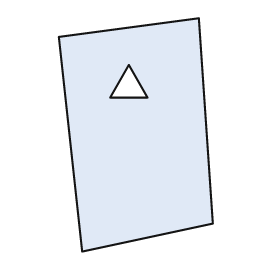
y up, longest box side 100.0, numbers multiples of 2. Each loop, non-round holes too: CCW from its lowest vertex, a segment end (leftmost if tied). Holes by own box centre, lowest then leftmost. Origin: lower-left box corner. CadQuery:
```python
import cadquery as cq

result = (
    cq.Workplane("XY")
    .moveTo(10.0, 0.0)
    .lineTo(66.0, 12.0)
    .lineTo(60.0, 100.0)
    .lineTo(0.0, 92.0)
    .close()
    .moveTo(22.0, 66.0)
    .lineTo(38.0, 66.0)
    .lineTo(30.0, 80.0)
    .close()
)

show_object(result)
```